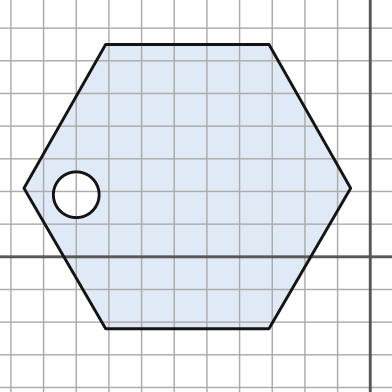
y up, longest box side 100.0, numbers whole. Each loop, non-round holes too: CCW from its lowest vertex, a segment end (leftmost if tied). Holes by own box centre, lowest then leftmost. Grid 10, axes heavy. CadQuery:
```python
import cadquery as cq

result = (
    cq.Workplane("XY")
    .moveTo(-81.0, -22.0)
    .lineTo(-31.0, -22.0)
    .lineTo(-6.0, 21.0)
    .lineTo(-31.0, 65.0)
    .lineTo(-81.0, 65.0)
    .lineTo(-106.0, 21.0)
    .close()
    .moveTo(-90.0, 19.0)
    .circle(7.0)
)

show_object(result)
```